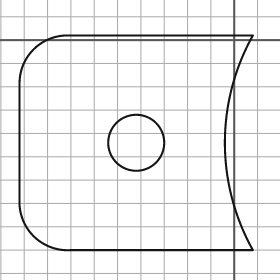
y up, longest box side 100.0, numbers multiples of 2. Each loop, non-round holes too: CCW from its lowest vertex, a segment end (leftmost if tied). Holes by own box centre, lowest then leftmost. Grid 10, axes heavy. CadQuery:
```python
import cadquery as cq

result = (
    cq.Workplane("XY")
    .moveTo(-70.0, -90.0)
    .lineTo(8.0, -90.0)
    .threePointArc((-4.0, -44.0), (8.0, 2.0))
    .lineTo(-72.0, 2.0)
    .threePointArc((-86.0, -4.0), (-92.0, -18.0))
    .lineTo(-92.0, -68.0)
    .threePointArc((-86.0, -84.0), (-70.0, -90.0))
    .close()
    .moveTo(-42.0, -44.0)
    .circle(12.0)
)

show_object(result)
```